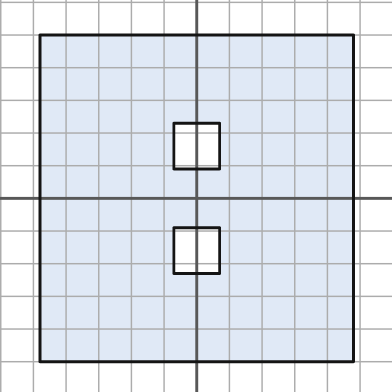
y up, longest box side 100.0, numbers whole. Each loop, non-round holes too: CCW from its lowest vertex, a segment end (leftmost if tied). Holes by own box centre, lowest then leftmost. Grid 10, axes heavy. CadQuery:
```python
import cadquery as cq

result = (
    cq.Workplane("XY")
    .moveTo(-48.0, -50.0)
    .lineTo(48.0, -50.0)
    .lineTo(48.0, 50.0)
    .lineTo(-48.0, 50.0)
    .close()
    .moveTo(-7.0, -23.0)
    .lineTo(7.0, -23.0)
    .lineTo(7.0, -9.0)
    .lineTo(-7.0, -9.0)
    .close()
    .moveTo(-7.0, 9.0)
    .lineTo(7.0, 9.0)
    .lineTo(7.0, 23.0)
    .lineTo(-7.0, 23.0)
    .close()
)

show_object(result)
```